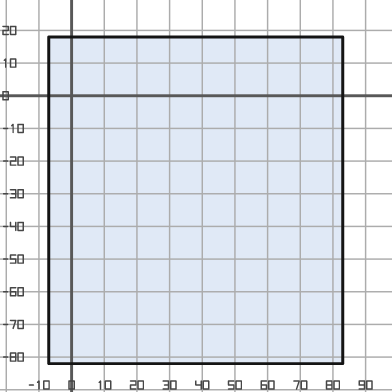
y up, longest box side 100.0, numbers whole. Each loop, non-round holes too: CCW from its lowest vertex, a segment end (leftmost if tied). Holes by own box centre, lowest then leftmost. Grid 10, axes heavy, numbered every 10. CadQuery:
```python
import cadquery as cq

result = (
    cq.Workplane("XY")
    .moveTo(-7.0, -82.0)
    .lineTo(83.0, -82.0)
    .lineTo(83.0, 18.0)
    .lineTo(-7.0, 18.0)
    .close()
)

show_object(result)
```